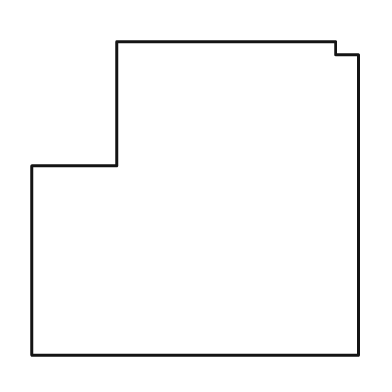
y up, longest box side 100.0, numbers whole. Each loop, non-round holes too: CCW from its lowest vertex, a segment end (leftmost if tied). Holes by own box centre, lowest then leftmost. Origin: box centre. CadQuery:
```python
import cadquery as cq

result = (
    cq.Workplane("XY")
    .moveTo(-50.0, -48.0)
    .lineTo(50.0, -48.0)
    .lineTo(50.0, 44.0)
    .lineTo(43.0, 44.0)
    .lineTo(43.0, 48.0)
    .lineTo(-24.0, 48.0)
    .lineTo(-24.0, 10.0)
    .lineTo(-50.0, 10.0)
    .close()
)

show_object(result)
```